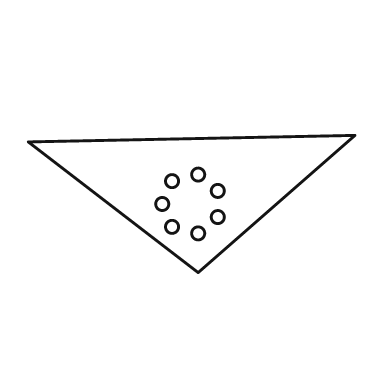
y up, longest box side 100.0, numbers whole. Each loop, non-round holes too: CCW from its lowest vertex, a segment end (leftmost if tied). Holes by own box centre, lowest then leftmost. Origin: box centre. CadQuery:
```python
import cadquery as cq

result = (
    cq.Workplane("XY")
    .moveTo(2.0, -21.0)
    .lineTo(50.0, 21.0)
    .lineTo(-50.0, 19.0)
    .close()
    .moveTo(2.0, -9.0)
    .circle(2.0)
    .moveTo(-6.0, -7.0)
    .circle(2.0)
    .moveTo(8.0, -4.0)
    .circle(2.0)
    .moveTo(-9.0, 0.0)
    .circle(2.0)
    .moveTo(8.0, 4.0)
    .circle(2.0)
    .moveTo(-6.0, 7.0)
    .circle(2.0)
    .moveTo(2.0, 9.0)
    .circle(2.0)
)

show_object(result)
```